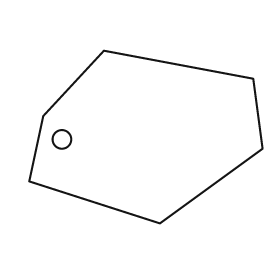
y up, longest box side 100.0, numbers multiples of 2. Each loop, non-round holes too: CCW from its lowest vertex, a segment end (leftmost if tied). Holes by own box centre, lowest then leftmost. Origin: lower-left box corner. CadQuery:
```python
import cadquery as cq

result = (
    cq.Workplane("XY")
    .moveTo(56.0, 0.0)
    .lineTo(100.0, 32.0)
    .lineTo(96.0, 62.0)
    .lineTo(32.0, 74.0)
    .lineTo(6.0, 46.0)
    .lineTo(0.0, 18.0)
    .close()
    .moveTo(14.0, 36.0)
    .circle(4.0)
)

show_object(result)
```